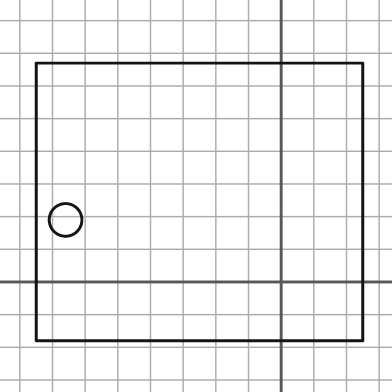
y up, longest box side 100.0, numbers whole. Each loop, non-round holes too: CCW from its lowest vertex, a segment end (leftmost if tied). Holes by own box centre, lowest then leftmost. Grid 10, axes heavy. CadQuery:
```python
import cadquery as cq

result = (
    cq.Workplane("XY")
    .moveTo(-75.0, -18.0)
    .lineTo(25.0, -18.0)
    .lineTo(25.0, 67.0)
    .lineTo(-75.0, 67.0)
    .close()
    .moveTo(-66.0, 19.0)
    .circle(5.0)
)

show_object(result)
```